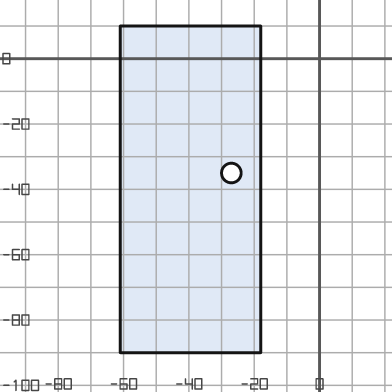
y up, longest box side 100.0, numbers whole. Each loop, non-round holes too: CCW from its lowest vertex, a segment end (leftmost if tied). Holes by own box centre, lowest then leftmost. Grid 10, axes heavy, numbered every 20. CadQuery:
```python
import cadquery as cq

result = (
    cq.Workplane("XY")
    .moveTo(-61.0, -90.0)
    .lineTo(-18.0, -90.0)
    .lineTo(-18.0, 10.0)
    .lineTo(-61.0, 10.0)
    .close()
    .moveTo(-27.0, -35.0)
    .circle(3.0)
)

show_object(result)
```